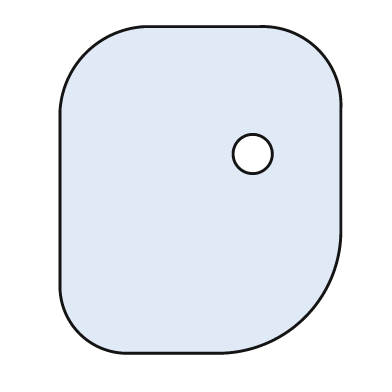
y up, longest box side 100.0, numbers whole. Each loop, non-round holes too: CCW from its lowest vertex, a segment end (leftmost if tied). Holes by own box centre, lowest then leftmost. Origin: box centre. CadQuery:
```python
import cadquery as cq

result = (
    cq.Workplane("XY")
    .moveTo(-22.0, -50.0)
    .lineTo(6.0, -50.0)
    .threePointArc((32.0, -39.0), (43.0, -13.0))
    .lineTo(43.0, 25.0)
    .threePointArc((36.0, 43.0), (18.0, 50.0))
    .lineTo(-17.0, 50.0)
    .threePointArc((-35.0, 42.0), (-43.0, 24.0))
    .lineTo(-43.0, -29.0)
    .threePointArc((-37.0, -44.0), (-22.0, -50.0))
    .close()
    .moveTo(16.0, 11.0)
    .circle(6.0)
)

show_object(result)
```